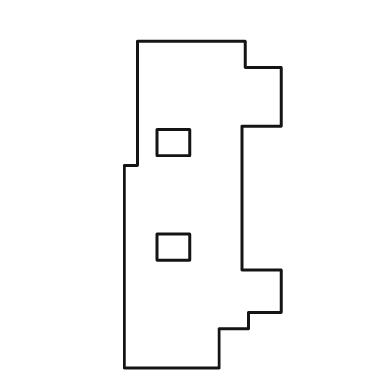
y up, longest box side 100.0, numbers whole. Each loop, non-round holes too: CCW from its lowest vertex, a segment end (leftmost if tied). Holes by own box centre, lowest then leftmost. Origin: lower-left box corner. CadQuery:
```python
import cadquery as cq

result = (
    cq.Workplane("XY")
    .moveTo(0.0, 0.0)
    .lineTo(29.0, 0.0)
    .lineTo(29.0, 12.0)
    .lineTo(38.0, 12.0)
    .lineTo(38.0, 17.0)
    .lineTo(48.0, 17.0)
    .lineTo(48.0, 30.0)
    .lineTo(36.0, 30.0)
    .lineTo(36.0, 74.0)
    .lineTo(48.0, 74.0)
    .lineTo(48.0, 92.0)
    .lineTo(37.0, 92.0)
    .lineTo(37.0, 100.0)
    .lineTo(4.0, 100.0)
    .lineTo(4.0, 62.0)
    .lineTo(0.0, 62.0)
    .close()
    .moveTo(10.0, 33.0)
    .lineTo(20.0, 33.0)
    .lineTo(20.0, 41.0)
    .lineTo(10.0, 41.0)
    .close()
    .moveTo(10.0, 65.0)
    .lineTo(20.0, 65.0)
    .lineTo(20.0, 73.0)
    .lineTo(10.0, 73.0)
    .close()
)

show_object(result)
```